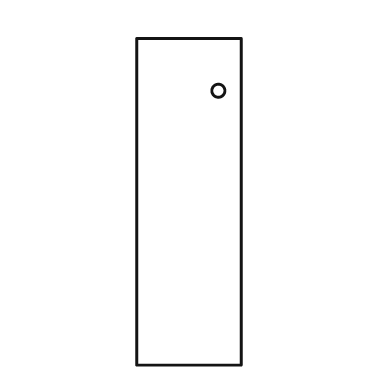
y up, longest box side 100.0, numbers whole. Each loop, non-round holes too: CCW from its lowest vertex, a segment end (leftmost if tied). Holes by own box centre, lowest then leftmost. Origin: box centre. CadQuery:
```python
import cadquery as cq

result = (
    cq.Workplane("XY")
    .moveTo(-16.0, -50.0)
    .lineTo(16.0, -50.0)
    .lineTo(16.0, 50.0)
    .lineTo(-16.0, 50.0)
    .close()
    .moveTo(9.0, 34.0)
    .circle(2.0)
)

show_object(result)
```